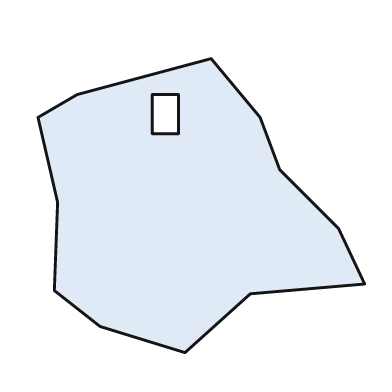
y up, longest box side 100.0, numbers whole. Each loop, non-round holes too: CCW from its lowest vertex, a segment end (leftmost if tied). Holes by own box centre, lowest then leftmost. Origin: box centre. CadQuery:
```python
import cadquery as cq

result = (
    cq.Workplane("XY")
    .moveTo(-5.0, -45.0)
    .lineTo(15.0, -27.0)
    .lineTo(50.0, -24.0)
    .lineTo(42.0, -7.0)
    .lineTo(24.0, 11.0)
    .lineTo(18.0, 27.0)
    .lineTo(3.0, 45.0)
    .lineTo(-38.0, 34.0)
    .lineTo(-50.0, 27.0)
    .lineTo(-44.0, 1.0)
    .lineTo(-45.0, -26.0)
    .lineTo(-31.0, -37.0)
    .close()
    .moveTo(-15.0, 22.0)
    .lineTo(-7.0, 22.0)
    .lineTo(-7.0, 34.0)
    .lineTo(-15.0, 34.0)
    .close()
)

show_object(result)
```